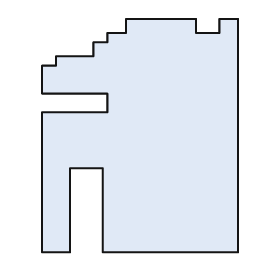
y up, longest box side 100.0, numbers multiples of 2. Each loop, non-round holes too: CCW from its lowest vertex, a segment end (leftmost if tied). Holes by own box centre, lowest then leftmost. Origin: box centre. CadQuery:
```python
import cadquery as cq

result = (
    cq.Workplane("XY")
    .moveTo(-42.0, -50.0)
    .lineTo(-30.0, -50.0)
    .lineTo(-30.0, -14.0)
    .lineTo(-16.0, -14.0)
    .lineTo(-16.0, -50.0)
    .lineTo(42.0, -50.0)
    .lineTo(42.0, 50.0)
    .lineTo(34.0, 50.0)
    .lineTo(34.0, 44.0)
    .lineTo(24.0, 44.0)
    .lineTo(24.0, 50.0)
    .lineTo(-6.0, 50.0)
    .lineTo(-6.0, 44.0)
    .lineTo(-14.0, 44.0)
    .lineTo(-14.0, 40.0)
    .lineTo(-20.0, 40.0)
    .lineTo(-20.0, 34.0)
    .lineTo(-36.0, 34.0)
    .lineTo(-36.0, 30.0)
    .lineTo(-42.0, 30.0)
    .lineTo(-42.0, 18.0)
    .lineTo(-14.0, 18.0)
    .lineTo(-14.0, 10.0)
    .lineTo(-42.0, 10.0)
    .close()
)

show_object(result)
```